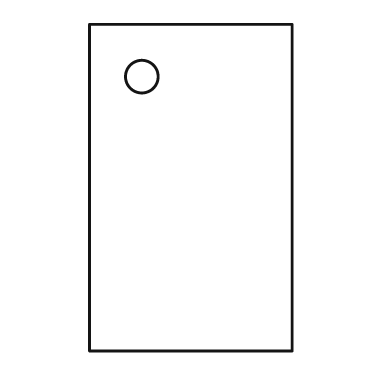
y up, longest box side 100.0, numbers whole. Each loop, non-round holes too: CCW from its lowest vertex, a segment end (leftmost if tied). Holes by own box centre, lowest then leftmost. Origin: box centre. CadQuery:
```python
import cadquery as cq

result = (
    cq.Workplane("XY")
    .moveTo(-31.0, -50.0)
    .lineTo(31.0, -50.0)
    .lineTo(31.0, 50.0)
    .lineTo(-31.0, 50.0)
    .close()
    .moveTo(-15.0, 34.0)
    .circle(5.0)
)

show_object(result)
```